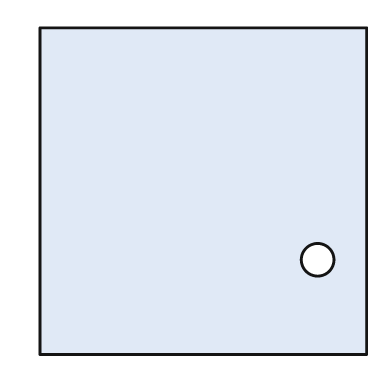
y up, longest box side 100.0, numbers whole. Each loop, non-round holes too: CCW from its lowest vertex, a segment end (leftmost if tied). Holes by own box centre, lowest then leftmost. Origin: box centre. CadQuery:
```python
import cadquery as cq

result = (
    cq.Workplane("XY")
    .moveTo(-50.0, -50.0)
    .lineTo(50.0, -50.0)
    .lineTo(50.0, 50.0)
    .lineTo(-50.0, 50.0)
    .close()
    .moveTo(35.0, -21.0)
    .circle(5.0)
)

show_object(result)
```